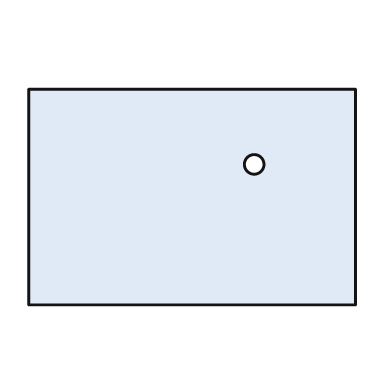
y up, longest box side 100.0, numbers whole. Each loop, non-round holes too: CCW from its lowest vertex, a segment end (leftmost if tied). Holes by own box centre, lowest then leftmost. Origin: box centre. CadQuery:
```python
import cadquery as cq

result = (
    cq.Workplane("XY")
    .moveTo(-50.0, -33.0)
    .lineTo(50.0, -33.0)
    .lineTo(50.0, 33.0)
    .lineTo(-50.0, 33.0)
    .close()
    .moveTo(19.0, 10.0)
    .circle(3.0)
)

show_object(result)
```